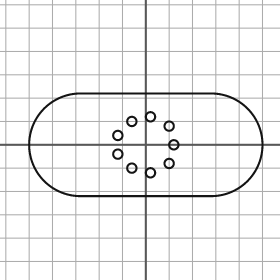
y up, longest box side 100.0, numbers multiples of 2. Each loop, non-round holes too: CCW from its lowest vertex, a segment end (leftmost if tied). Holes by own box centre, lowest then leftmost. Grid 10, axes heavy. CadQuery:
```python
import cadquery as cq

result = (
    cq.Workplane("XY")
    .moveTo(-28.0, -22.0)
    .lineTo(28.0, -22.0)
    .threePointArc((50.0, 0.0), (28.0, 22.0))
    .lineTo(-28.0, 22.0)
    .threePointArc((-50.0, 0.0), (-28.0, -22.0))
    .close()
    .moveTo(2.0, -12.0)
    .circle(2.0)
    .moveTo(-6.0, -10.0)
    .circle(2.0)
    .moveTo(10.0, -8.0)
    .circle(2.0)
    .moveTo(-12.0, -4.0)
    .circle(2.0)
    .moveTo(12.0, 0.0)
    .circle(2.0)
    .moveTo(-12.0, 4.0)
    .circle(2.0)
    .moveTo(10.0, 8.0)
    .circle(2.0)
    .moveTo(-6.0, 10.0)
    .circle(2.0)
    .moveTo(2.0, 12.0)
    .circle(2.0)
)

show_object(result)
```